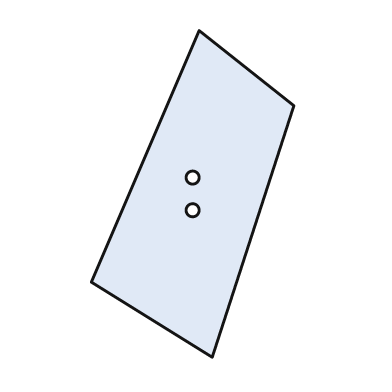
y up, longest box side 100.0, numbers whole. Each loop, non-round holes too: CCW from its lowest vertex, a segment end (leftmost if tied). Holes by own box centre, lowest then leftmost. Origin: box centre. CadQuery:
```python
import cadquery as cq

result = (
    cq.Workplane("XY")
    .moveTo(6.0, -50.0)
    .lineTo(31.0, 27.0)
    .lineTo(2.0, 50.0)
    .lineTo(-31.0, -27.0)
    .close()
    .moveTo(0.0, -5.0)
    .circle(2.0)
    .moveTo(0.0, 5.0)
    .circle(2.0)
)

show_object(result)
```